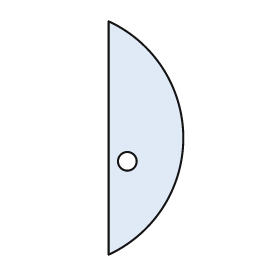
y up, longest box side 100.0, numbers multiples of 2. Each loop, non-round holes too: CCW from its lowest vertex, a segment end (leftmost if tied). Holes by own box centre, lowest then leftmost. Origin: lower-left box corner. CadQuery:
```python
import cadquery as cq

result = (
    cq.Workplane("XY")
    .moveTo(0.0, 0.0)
    .threePointArc((32.0, 50.0), (0.0, 100.0))
    .close()
    .moveTo(8.0, 40.0)
    .circle(4.0)
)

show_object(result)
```